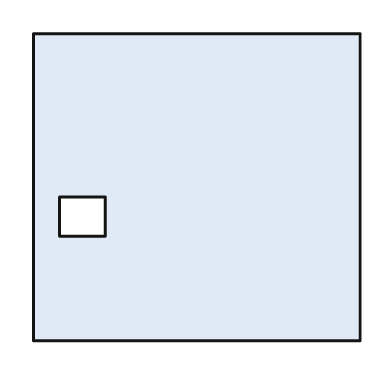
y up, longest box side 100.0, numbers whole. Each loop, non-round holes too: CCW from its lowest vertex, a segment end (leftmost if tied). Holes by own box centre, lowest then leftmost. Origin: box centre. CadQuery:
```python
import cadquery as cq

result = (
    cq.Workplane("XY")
    .moveTo(-50.0, -47.0)
    .lineTo(50.0, -47.0)
    .lineTo(50.0, 47.0)
    .lineTo(-50.0, 47.0)
    .close()
    .moveTo(-42.0, -15.0)
    .lineTo(-28.0, -15.0)
    .lineTo(-28.0, -3.0)
    .lineTo(-42.0, -3.0)
    .close()
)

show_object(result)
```